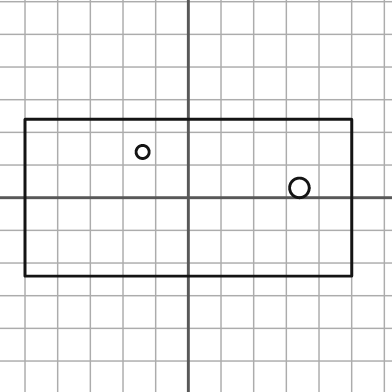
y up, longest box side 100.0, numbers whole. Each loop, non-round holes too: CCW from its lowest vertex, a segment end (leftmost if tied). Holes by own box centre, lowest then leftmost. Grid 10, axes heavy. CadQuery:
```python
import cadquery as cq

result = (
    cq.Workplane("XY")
    .moveTo(-50.0, -24.0)
    .lineTo(50.0, -24.0)
    .lineTo(50.0, 24.0)
    .lineTo(-50.0, 24.0)
    .close()
    .moveTo(34.0, 3.0)
    .circle(3.0)
    .moveTo(-14.0, 14.0)
    .circle(2.0)
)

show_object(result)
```